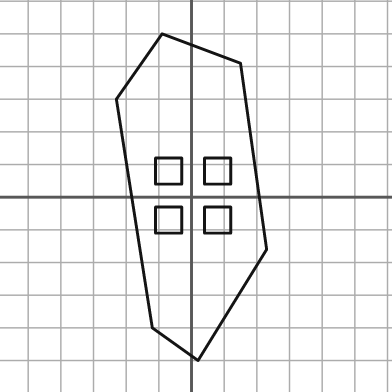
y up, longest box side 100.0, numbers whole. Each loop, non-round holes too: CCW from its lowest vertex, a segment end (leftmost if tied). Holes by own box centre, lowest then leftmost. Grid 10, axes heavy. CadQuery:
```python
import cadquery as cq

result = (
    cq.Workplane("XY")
    .moveTo(2.0, -50.0)
    .lineTo(23.0, -16.0)
    .lineTo(15.0, 41.0)
    .lineTo(-9.0, 50.0)
    .lineTo(-23.0, 30.0)
    .lineTo(-12.0, -40.0)
    .close()
    .moveTo(-11.0, -11.0)
    .lineTo(-3.0, -11.0)
    .lineTo(-3.0, -3.0)
    .lineTo(-11.0, -3.0)
    .close()
    .moveTo(4.0, -11.0)
    .lineTo(12.0, -11.0)
    .lineTo(12.0, -3.0)
    .lineTo(4.0, -3.0)
    .close()
    .moveTo(-11.0, 4.0)
    .lineTo(-3.0, 4.0)
    .lineTo(-3.0, 12.0)
    .lineTo(-11.0, 12.0)
    .close()
    .moveTo(4.0, 4.0)
    .lineTo(12.0, 4.0)
    .lineTo(12.0, 12.0)
    .lineTo(4.0, 12.0)
    .close()
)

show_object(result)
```